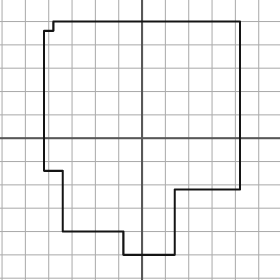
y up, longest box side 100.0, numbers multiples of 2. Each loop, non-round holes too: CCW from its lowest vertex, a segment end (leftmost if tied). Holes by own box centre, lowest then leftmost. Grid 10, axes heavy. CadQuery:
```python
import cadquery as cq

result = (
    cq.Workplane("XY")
    .moveTo(-8.0, -50.0)
    .lineTo(14.0, -50.0)
    .lineTo(14.0, -22.0)
    .lineTo(42.0, -22.0)
    .lineTo(42.0, 50.0)
    .lineTo(-38.0, 50.0)
    .lineTo(-38.0, 46.0)
    .lineTo(-42.0, 46.0)
    .lineTo(-42.0, -14.0)
    .lineTo(-34.0, -14.0)
    .lineTo(-34.0, -40.0)
    .lineTo(-8.0, -40.0)
    .close()
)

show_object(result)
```